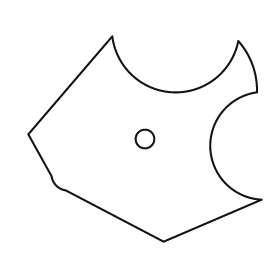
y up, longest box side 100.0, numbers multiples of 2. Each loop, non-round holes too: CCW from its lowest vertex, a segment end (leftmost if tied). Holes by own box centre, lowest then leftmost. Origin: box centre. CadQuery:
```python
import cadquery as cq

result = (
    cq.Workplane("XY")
    .moveTo(8.0, -44.0)
    .lineTo(50.0, -26.0)
    .threePointArc((28.0, -4.0), (48.0, 20.0))
    .threePointArc((46.0, 32.0), (40.0, 42.0))
    .threePointArc((12.0, 20.0), (-14.0, 44.0))
    .lineTo(-50.0, 2.0)
    .lineTo(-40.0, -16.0)
    .threePointArc((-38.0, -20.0), (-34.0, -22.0))
    .close()
    .moveTo(0.0, 0.0)
    .circle(4.0)
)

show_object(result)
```